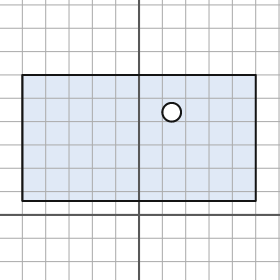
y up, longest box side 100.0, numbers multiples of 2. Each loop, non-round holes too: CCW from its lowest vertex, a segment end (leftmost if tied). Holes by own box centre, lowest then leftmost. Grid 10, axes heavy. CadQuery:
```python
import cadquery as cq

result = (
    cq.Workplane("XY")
    .moveTo(-50.0, 6.0)
    .lineTo(50.0, 6.0)
    .lineTo(50.0, 60.0)
    .lineTo(-50.0, 60.0)
    .close()
    .moveTo(14.0, 44.0)
    .circle(4.0)
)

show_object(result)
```